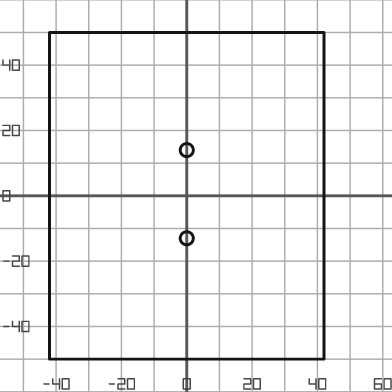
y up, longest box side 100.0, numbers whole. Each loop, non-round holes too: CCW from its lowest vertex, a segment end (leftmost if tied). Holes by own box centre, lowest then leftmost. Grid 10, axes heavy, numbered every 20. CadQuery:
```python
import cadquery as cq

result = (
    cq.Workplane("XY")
    .moveTo(-42.0, -50.0)
    .lineTo(42.0, -50.0)
    .lineTo(42.0, 50.0)
    .lineTo(-42.0, 50.0)
    .close()
    .moveTo(0.0, -13.0)
    .circle(2.0)
    .moveTo(0.0, 14.0)
    .circle(2.0)
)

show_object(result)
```